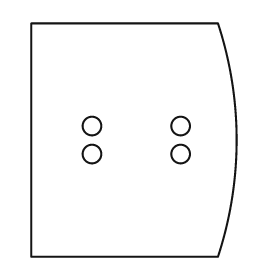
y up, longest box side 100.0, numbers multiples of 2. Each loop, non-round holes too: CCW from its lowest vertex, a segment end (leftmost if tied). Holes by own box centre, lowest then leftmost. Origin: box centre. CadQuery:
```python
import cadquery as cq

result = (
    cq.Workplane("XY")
    .moveTo(-44.0, -50.0)
    .lineTo(36.0, -50.0)
    .threePointArc((44.0, 0.0), (36.0, 50.0))
    .lineTo(-44.0, 50.0)
    .close()
    .moveTo(-18.0, -6.0)
    .circle(4.0)
    .moveTo(20.0, -6.0)
    .circle(4.0)
    .moveTo(-18.0, 6.0)
    .circle(4.0)
    .moveTo(20.0, 6.0)
    .circle(4.0)
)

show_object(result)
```